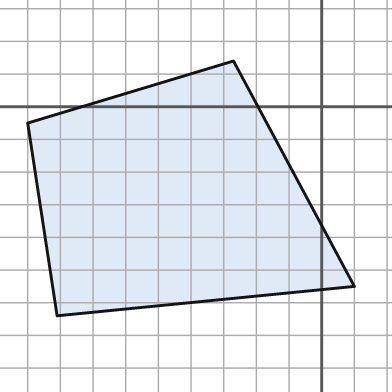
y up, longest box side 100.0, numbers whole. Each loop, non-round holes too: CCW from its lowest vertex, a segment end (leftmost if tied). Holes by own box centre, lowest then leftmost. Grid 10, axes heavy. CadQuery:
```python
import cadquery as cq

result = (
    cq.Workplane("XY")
    .moveTo(-81.0, -64.0)
    .lineTo(10.0, -55.0)
    .lineTo(-27.0, 14.0)
    .lineTo(-90.0, -5.0)
    .close()
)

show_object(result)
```